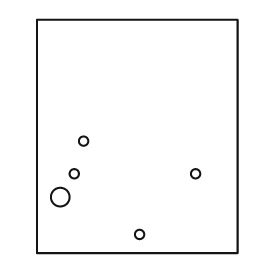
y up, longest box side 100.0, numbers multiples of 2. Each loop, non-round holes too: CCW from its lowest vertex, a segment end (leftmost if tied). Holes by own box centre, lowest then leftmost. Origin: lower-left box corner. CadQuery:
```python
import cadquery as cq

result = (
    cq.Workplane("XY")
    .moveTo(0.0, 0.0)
    .lineTo(86.0, 0.0)
    .lineTo(86.0, 100.0)
    .lineTo(0.0, 100.0)
    .close()
    .moveTo(44.0, 8.0)
    .circle(2.0)
    .moveTo(10.0, 24.0)
    .circle(4.0)
    .moveTo(16.0, 34.0)
    .circle(2.0)
    .moveTo(68.0, 34.0)
    .circle(2.0)
    .moveTo(20.0, 48.0)
    .circle(2.0)
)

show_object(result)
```